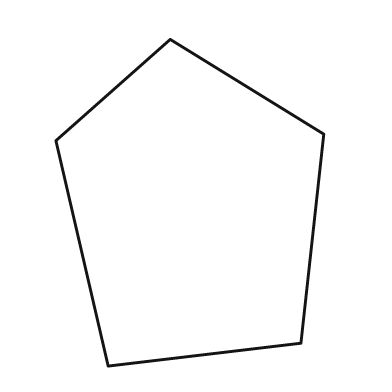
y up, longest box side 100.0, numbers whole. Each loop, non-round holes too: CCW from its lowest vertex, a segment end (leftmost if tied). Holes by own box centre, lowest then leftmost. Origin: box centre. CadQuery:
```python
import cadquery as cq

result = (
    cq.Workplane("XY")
    .moveTo(-25.0, -50.0)
    .lineTo(34.0, -43.0)
    .lineTo(41.0, 21.0)
    .lineTo(-6.0, 50.0)
    .lineTo(-41.0, 19.0)
    .close()
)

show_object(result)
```